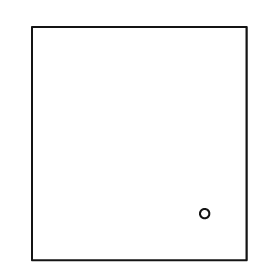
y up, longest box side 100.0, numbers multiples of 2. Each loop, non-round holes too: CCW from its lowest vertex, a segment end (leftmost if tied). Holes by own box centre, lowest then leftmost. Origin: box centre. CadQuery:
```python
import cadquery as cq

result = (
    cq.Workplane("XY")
    .moveTo(-46.0, -50.0)
    .lineTo(46.0, -50.0)
    .lineTo(46.0, 50.0)
    .lineTo(-46.0, 50.0)
    .close()
    .moveTo(28.0, -30.0)
    .circle(2.0)
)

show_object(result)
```